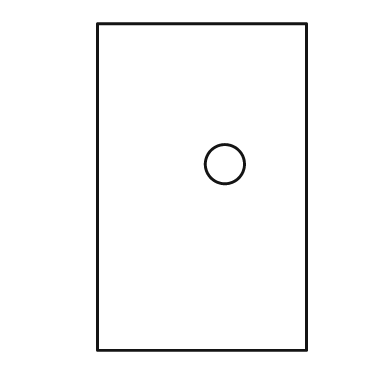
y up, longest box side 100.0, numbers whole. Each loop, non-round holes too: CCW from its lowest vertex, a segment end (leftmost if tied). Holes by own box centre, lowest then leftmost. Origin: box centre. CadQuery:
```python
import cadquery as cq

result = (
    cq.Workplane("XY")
    .moveTo(-32.0, -50.0)
    .lineTo(32.0, -50.0)
    .lineTo(32.0, 50.0)
    .lineTo(-32.0, 50.0)
    .close()
    .moveTo(7.0, 7.0)
    .circle(6.0)
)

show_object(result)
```